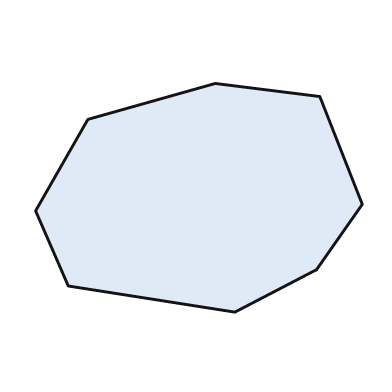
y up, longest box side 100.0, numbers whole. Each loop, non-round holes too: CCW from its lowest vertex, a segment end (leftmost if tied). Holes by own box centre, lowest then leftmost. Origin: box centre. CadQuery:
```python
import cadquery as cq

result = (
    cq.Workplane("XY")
    .moveTo(11.0, -35.0)
    .lineTo(36.0, -22.0)
    .lineTo(50.0, -2.0)
    .lineTo(37.0, 31.0)
    .lineTo(5.0, 35.0)
    .lineTo(-34.0, 24.0)
    .lineTo(-50.0, -4.0)
    .lineTo(-40.0, -27.0)
    .close()
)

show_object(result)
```